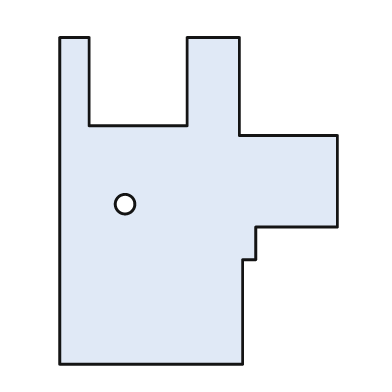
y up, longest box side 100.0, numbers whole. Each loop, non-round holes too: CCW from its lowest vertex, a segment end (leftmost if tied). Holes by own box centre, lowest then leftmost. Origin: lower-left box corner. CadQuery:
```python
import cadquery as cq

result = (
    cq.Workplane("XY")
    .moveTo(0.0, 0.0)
    .lineTo(56.0, 0.0)
    .lineTo(56.0, 32.0)
    .lineTo(60.0, 32.0)
    .lineTo(60.0, 42.0)
    .lineTo(85.0, 42.0)
    .lineTo(85.0, 70.0)
    .lineTo(55.0, 70.0)
    .lineTo(55.0, 100.0)
    .lineTo(39.0, 100.0)
    .lineTo(39.0, 73.0)
    .lineTo(9.0, 73.0)
    .lineTo(9.0, 100.0)
    .lineTo(0.0, 100.0)
    .close()
    .moveTo(20.0, 49.0)
    .circle(3.0)
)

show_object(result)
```